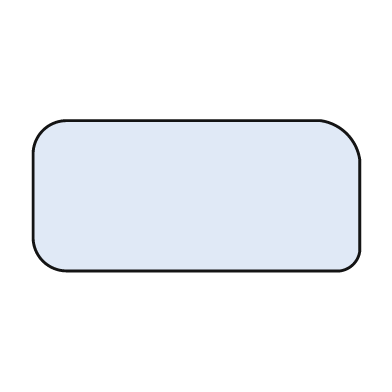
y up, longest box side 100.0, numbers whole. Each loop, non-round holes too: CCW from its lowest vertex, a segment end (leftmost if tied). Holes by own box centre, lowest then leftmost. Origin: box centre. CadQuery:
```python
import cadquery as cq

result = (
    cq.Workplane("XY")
    .moveTo(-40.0, -23.0)
    .lineTo(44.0, -23.0)
    .threePointArc((48.0, -21.0), (50.0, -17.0))
    .lineTo(50.0, 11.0)
    .threePointArc((46.0, 19.0), (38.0, 23.0))
    .lineTo(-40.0, 23.0)
    .threePointArc((-47.0, 20.0), (-50.0, 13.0))
    .lineTo(-50.0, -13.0)
    .threePointArc((-47.0, -20.0), (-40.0, -23.0))
    .close()
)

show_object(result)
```